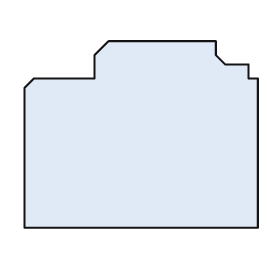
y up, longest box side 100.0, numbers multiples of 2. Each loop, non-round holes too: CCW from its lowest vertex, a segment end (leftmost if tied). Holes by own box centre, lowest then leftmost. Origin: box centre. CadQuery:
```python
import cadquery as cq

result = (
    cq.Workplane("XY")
    .moveTo(-50.0, -40.0)
    .lineTo(50.0, -40.0)
    .lineTo(50.0, 24.0)
    .lineTo(46.0, 24.0)
    .lineTo(46.0, 30.0)
    .lineTo(36.0, 30.0)
    .lineTo(32.0, 34.0)
    .lineTo(32.0, 40.0)
    .lineTo(-14.0, 40.0)
    .lineTo(-20.0, 34.0)
    .lineTo(-20.0, 24.0)
    .lineTo(-46.0, 24.0)
    .lineTo(-50.0, 20.0)
    .close()
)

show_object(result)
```